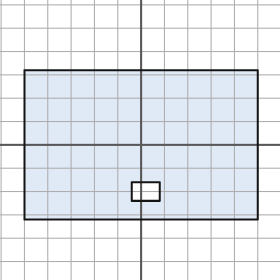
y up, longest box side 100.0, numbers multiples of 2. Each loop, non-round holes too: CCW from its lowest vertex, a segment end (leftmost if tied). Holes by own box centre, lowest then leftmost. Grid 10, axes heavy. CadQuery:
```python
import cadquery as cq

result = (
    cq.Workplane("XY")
    .moveTo(-50.0, -32.0)
    .lineTo(50.0, -32.0)
    .lineTo(50.0, 32.0)
    .lineTo(-50.0, 32.0)
    .close()
    .moveTo(-4.0, -24.0)
    .lineTo(8.0, -24.0)
    .lineTo(8.0, -16.0)
    .lineTo(-4.0, -16.0)
    .close()
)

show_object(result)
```